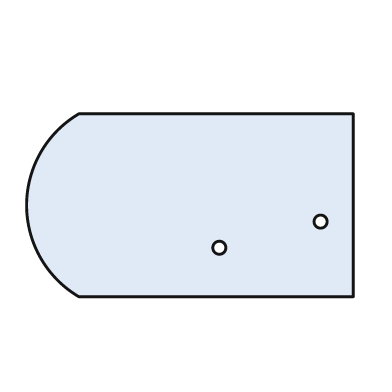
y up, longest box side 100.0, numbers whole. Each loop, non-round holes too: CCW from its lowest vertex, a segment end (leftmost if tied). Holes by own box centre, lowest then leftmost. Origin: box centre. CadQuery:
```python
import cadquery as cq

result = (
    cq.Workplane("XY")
    .moveTo(-34.0, -28.0)
    .lineTo(50.0, -28.0)
    .lineTo(50.0, 28.0)
    .lineTo(-34.0, 28.0)
    .threePointArc((-50.0, 0.0), (-34.0, -28.0))
    .close()
    .moveTo(9.0, -13.0)
    .circle(2.0)
    .moveTo(40.0, -5.0)
    .circle(2.0)
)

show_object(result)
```